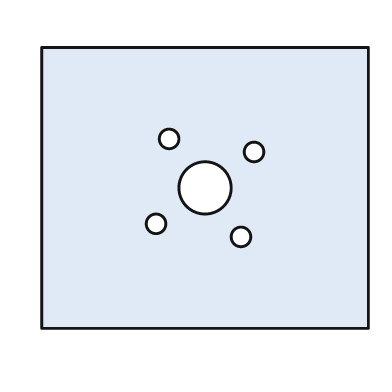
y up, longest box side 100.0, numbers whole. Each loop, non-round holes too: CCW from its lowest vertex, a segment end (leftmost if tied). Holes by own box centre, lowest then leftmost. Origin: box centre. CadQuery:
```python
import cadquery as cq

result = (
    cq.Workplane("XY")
    .moveTo(-50.0, -43.0)
    .lineTo(50.0, -43.0)
    .lineTo(50.0, 43.0)
    .lineTo(-50.0, 43.0)
    .close()
    .moveTo(11.0, -15.0)
    .circle(3.0)
    .moveTo(-15.0, -11.0)
    .circle(3.0)
    .moveTo(0.0, 0.0)
    .circle(8.0)
    .moveTo(15.0, 11.0)
    .circle(3.0)
    .moveTo(-11.0, 15.0)
    .circle(3.0)
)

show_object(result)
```